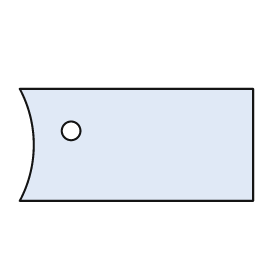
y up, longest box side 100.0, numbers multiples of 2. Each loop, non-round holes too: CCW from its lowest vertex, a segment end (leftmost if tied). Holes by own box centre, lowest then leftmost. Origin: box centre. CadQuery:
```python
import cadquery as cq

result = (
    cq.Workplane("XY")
    .moveTo(-50.0, -24.0)
    .lineTo(50.0, -24.0)
    .lineTo(50.0, 24.0)
    .lineTo(-50.0, 24.0)
    .threePointArc((-44.0, 0.0), (-50.0, -24.0))
    .close()
    .moveTo(-28.0, 6.0)
    .circle(4.0)
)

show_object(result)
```